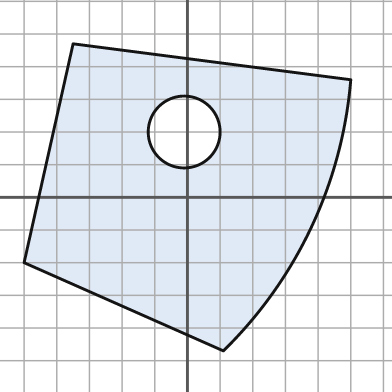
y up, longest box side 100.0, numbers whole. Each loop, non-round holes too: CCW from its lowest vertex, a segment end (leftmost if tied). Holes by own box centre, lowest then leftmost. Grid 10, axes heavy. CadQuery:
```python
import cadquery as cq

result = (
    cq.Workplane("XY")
    .moveTo(11.0, -47.0)
    .threePointArc((38.0, -9.0), (50.0, 36.0))
    .lineTo(-35.0, 47.0)
    .lineTo(-50.0, -20.0)
    .close()
    .moveTo(-1.0, 20.0)
    .circle(11.0)
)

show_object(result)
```